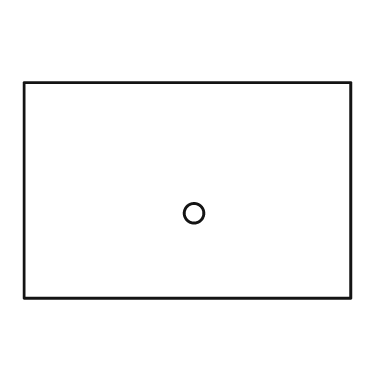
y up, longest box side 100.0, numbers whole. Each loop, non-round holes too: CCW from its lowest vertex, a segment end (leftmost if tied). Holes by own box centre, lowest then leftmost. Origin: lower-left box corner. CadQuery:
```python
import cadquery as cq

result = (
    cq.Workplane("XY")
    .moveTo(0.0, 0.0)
    .lineTo(100.0, 0.0)
    .lineTo(100.0, 66.0)
    .lineTo(0.0, 66.0)
    .close()
    .moveTo(52.0, 26.0)
    .circle(3.0)
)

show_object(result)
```